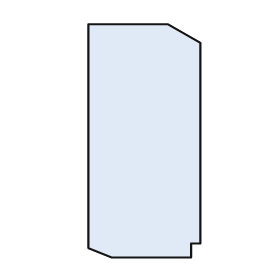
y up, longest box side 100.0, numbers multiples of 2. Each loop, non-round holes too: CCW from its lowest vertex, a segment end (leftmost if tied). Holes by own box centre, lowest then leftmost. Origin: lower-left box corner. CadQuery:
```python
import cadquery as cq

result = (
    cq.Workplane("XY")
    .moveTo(10.0, 0.0)
    .lineTo(44.0, 0.0)
    .lineTo(44.0, 6.0)
    .lineTo(48.0, 6.0)
    .lineTo(48.0, 92.0)
    .lineTo(34.0, 100.0)
    .lineTo(0.0, 100.0)
    .lineTo(0.0, 4.0)
    .close()
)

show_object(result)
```